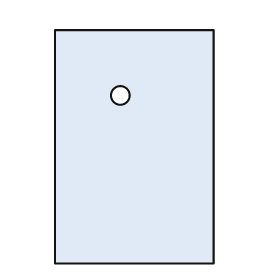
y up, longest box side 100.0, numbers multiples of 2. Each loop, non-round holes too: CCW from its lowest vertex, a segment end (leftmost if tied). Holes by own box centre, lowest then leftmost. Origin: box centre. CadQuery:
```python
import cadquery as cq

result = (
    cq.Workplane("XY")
    .moveTo(-34.0, -50.0)
    .lineTo(34.0, -50.0)
    .lineTo(34.0, 50.0)
    .lineTo(-34.0, 50.0)
    .close()
    .moveTo(-6.0, 22.0)
    .circle(4.0)
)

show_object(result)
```